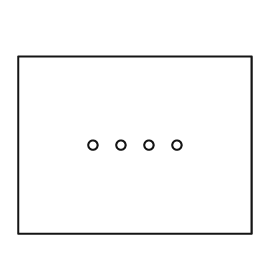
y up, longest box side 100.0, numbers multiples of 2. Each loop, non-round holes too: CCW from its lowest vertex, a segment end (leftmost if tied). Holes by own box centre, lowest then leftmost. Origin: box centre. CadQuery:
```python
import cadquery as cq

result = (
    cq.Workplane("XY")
    .moveTo(-50.0, -38.0)
    .lineTo(50.0, -38.0)
    .lineTo(50.0, 38.0)
    .lineTo(-50.0, 38.0)
    .close()
    .moveTo(-18.0, 0.0)
    .circle(2.0)
    .moveTo(-6.0, 0.0)
    .circle(2.0)
    .moveTo(6.0, 0.0)
    .circle(2.0)
    .moveTo(18.0, 0.0)
    .circle(2.0)
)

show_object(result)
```